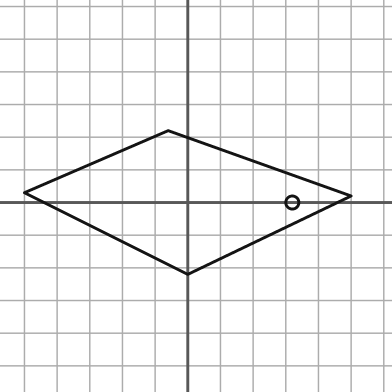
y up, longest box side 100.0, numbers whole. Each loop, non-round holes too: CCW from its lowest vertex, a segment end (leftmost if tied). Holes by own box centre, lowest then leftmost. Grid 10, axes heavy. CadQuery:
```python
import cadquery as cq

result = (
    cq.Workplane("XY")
    .moveTo(0.0, -22.0)
    .lineTo(50.0, 2.0)
    .lineTo(-6.0, 22.0)
    .lineTo(-50.0, 3.0)
    .close()
    .moveTo(32.0, 0.0)
    .circle(2.0)
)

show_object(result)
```